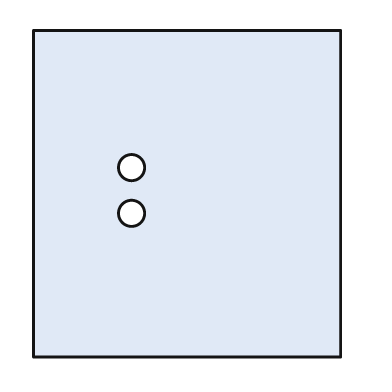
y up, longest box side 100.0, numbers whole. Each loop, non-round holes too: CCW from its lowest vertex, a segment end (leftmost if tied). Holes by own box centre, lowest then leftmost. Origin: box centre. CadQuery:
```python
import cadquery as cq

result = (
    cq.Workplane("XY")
    .moveTo(-47.0, -50.0)
    .lineTo(47.0, -50.0)
    .lineTo(47.0, 50.0)
    .lineTo(-47.0, 50.0)
    .close()
    .moveTo(-17.0, -6.0)
    .circle(4.0)
    .moveTo(-17.0, 8.0)
    .circle(4.0)
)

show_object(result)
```